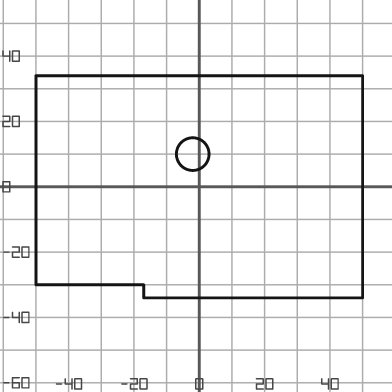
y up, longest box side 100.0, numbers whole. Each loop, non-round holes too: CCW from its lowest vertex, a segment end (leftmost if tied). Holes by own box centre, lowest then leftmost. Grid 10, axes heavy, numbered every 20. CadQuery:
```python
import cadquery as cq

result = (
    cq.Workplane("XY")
    .moveTo(-17.0, -34.0)
    .lineTo(50.0, -34.0)
    .lineTo(50.0, 34.0)
    .lineTo(-50.0, 34.0)
    .lineTo(-50.0, -30.0)
    .lineTo(-17.0, -30.0)
    .close()
    .moveTo(-2.0, 10.0)
    .circle(5.0)
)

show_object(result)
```